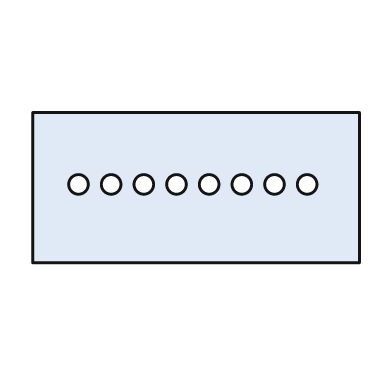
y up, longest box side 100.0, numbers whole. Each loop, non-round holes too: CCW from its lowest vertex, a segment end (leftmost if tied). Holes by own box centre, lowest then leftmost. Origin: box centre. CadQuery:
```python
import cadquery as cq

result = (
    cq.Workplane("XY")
    .moveTo(-50.0, -23.0)
    .lineTo(50.0, -23.0)
    .lineTo(50.0, 23.0)
    .lineTo(-50.0, 23.0)
    .close()
    .moveTo(-36.0, 1.0)
    .circle(3.0)
    .moveTo(-26.0, 1.0)
    .circle(3.0)
    .moveTo(-16.0, 1.0)
    .circle(3.0)
    .moveTo(-6.0, 1.0)
    .circle(3.0)
    .moveTo(4.0, 1.0)
    .circle(3.0)
    .moveTo(14.0, 1.0)
    .circle(3.0)
    .moveTo(24.0, 1.0)
    .circle(3.0)
    .moveTo(34.0, 1.0)
    .circle(3.0)
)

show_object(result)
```